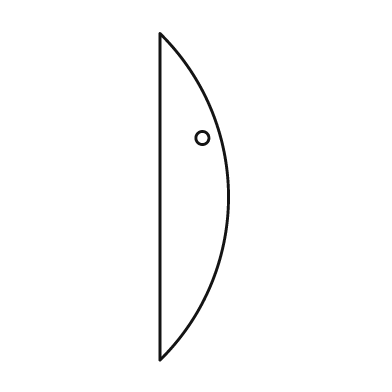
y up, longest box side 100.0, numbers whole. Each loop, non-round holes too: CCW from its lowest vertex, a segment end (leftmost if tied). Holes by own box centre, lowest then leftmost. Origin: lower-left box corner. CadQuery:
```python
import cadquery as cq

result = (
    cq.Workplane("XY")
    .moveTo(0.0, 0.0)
    .threePointArc((21.0, 50.0), (0.0, 100.0))
    .close()
    .moveTo(13.0, 68.0)
    .circle(2.0)
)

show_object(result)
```